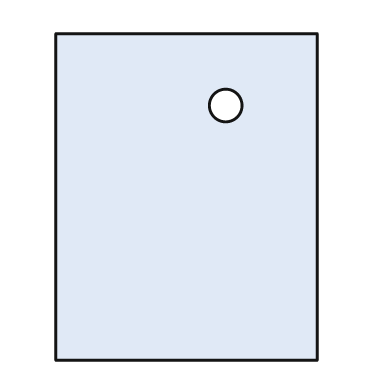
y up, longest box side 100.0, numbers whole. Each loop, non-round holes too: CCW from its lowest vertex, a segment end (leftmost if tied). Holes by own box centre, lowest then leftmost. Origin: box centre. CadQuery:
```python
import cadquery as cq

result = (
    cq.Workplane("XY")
    .moveTo(-40.0, -50.0)
    .lineTo(40.0, -50.0)
    .lineTo(40.0, 50.0)
    .lineTo(-40.0, 50.0)
    .close()
    .moveTo(12.0, 28.0)
    .circle(5.0)
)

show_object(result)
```